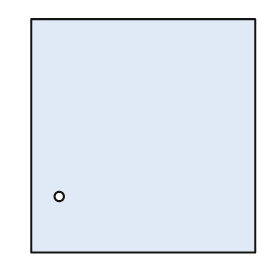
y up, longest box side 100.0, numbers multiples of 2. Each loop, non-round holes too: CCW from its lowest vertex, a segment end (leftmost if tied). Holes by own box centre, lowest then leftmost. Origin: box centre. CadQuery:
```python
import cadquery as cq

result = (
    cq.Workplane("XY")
    .moveTo(-48.0, -50.0)
    .lineTo(48.0, -50.0)
    .lineTo(48.0, 50.0)
    .lineTo(-48.0, 50.0)
    .close()
    .moveTo(-36.0, -26.0)
    .circle(2.0)
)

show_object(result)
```